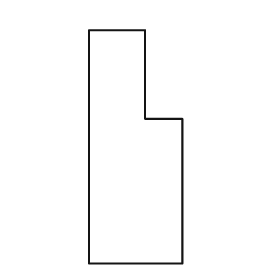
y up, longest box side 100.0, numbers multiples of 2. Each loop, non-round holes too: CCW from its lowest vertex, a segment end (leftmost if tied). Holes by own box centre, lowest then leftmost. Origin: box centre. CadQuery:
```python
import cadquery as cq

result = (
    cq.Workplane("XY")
    .moveTo(-20.0, -50.0)
    .lineTo(20.0, -50.0)
    .lineTo(20.0, 12.0)
    .lineTo(4.0, 12.0)
    .lineTo(4.0, 50.0)
    .lineTo(-20.0, 50.0)
    .close()
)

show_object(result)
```